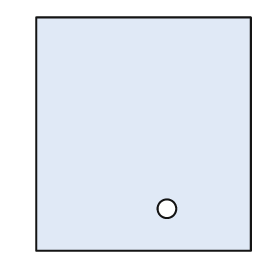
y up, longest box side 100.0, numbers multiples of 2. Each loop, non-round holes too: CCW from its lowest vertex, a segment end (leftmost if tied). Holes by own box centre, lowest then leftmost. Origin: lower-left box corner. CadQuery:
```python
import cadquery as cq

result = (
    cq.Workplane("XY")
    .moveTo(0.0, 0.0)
    .lineTo(92.0, 0.0)
    .lineTo(92.0, 100.0)
    .lineTo(0.0, 100.0)
    .close()
    .moveTo(56.0, 18.0)
    .circle(4.0)
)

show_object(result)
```